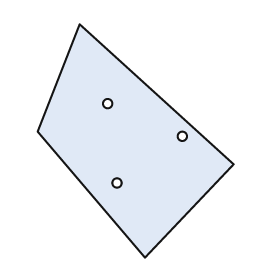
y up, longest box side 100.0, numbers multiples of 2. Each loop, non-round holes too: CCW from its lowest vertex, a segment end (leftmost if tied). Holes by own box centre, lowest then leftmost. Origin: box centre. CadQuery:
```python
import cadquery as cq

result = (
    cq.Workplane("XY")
    .moveTo(4.0, -50.0)
    .lineTo(42.0, -10.0)
    .lineTo(-24.0, 50.0)
    .lineTo(-42.0, 4.0)
    .close()
    .moveTo(-8.0, -18.0)
    .circle(2.0)
    .moveTo(20.0, 2.0)
    .circle(2.0)
    .moveTo(-12.0, 16.0)
    .circle(2.0)
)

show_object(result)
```